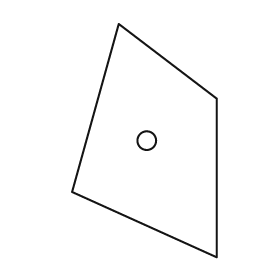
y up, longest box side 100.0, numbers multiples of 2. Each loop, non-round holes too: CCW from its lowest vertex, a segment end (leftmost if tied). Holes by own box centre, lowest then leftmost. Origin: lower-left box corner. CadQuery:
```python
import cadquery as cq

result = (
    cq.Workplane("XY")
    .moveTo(62.0, 0.0)
    .lineTo(62.0, 68.0)
    .lineTo(20.0, 100.0)
    .lineTo(0.0, 28.0)
    .close()
    .moveTo(32.0, 50.0)
    .circle(4.0)
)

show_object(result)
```